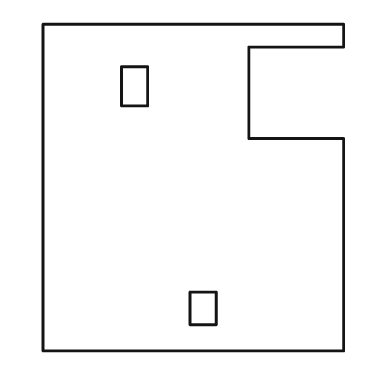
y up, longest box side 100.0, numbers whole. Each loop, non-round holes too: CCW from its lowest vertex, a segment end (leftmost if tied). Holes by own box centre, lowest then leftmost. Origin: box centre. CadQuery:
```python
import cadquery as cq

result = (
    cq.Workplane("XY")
    .moveTo(-46.0, -50.0)
    .lineTo(46.0, -50.0)
    .lineTo(46.0, 15.0)
    .lineTo(17.0, 15.0)
    .lineTo(17.0, 43.0)
    .lineTo(46.0, 43.0)
    .lineTo(46.0, 50.0)
    .lineTo(-46.0, 50.0)
    .close()
    .moveTo(-1.0, -42.0)
    .lineTo(7.0, -42.0)
    .lineTo(7.0, -32.0)
    .lineTo(-1.0, -32.0)
    .close()
    .moveTo(-22.0, 25.0)
    .lineTo(-14.0, 25.0)
    .lineTo(-14.0, 37.0)
    .lineTo(-22.0, 37.0)
    .close()
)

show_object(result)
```